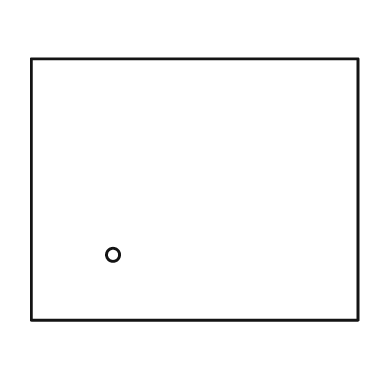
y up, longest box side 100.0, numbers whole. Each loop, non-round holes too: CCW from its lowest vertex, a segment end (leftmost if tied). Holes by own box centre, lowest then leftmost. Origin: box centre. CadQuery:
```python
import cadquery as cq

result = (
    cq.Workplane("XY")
    .moveTo(-50.0, -40.0)
    .lineTo(50.0, -40.0)
    .lineTo(50.0, 40.0)
    .lineTo(-50.0, 40.0)
    .close()
    .moveTo(-25.0, -20.0)
    .circle(2.0)
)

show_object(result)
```